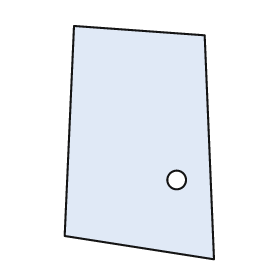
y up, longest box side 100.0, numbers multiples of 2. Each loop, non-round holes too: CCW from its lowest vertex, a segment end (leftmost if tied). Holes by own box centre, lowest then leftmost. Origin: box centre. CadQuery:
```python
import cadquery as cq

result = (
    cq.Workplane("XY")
    .moveTo(32.0, -50.0)
    .lineTo(28.0, 46.0)
    .lineTo(-28.0, 50.0)
    .lineTo(-32.0, -40.0)
    .close()
    .moveTo(16.0, -16.0)
    .circle(4.0)
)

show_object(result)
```